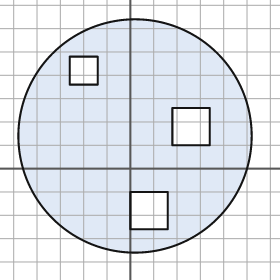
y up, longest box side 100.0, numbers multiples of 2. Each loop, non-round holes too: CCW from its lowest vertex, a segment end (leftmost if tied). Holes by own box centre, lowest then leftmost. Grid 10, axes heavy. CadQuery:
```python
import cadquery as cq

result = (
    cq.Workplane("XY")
    .moveTo(2.0, 14.0)
    .circle(50.0)
    .moveTo(0.0, -26.0)
    .lineTo(16.0, -26.0)
    .lineTo(16.0, -10.0)
    .lineTo(0.0, -10.0)
    .close()
    .moveTo(18.0, 10.0)
    .lineTo(34.0, 10.0)
    .lineTo(34.0, 26.0)
    .lineTo(18.0, 26.0)
    .close()
    .moveTo(-26.0, 36.0)
    .lineTo(-14.0, 36.0)
    .lineTo(-14.0, 48.0)
    .lineTo(-26.0, 48.0)
    .close()
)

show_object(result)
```